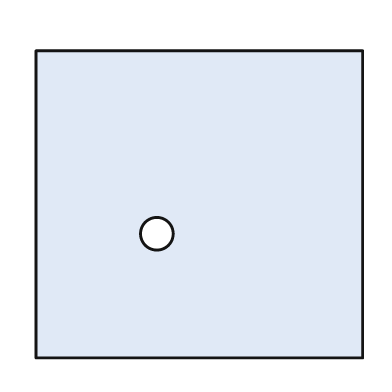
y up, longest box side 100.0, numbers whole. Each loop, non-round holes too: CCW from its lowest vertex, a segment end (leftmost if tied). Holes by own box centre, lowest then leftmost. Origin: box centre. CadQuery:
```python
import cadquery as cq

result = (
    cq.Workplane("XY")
    .moveTo(-50.0, -47.0)
    .lineTo(50.0, -47.0)
    .lineTo(50.0, 47.0)
    .lineTo(-50.0, 47.0)
    .close()
    .moveTo(-13.0, -9.0)
    .circle(5.0)
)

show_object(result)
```